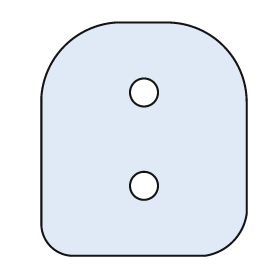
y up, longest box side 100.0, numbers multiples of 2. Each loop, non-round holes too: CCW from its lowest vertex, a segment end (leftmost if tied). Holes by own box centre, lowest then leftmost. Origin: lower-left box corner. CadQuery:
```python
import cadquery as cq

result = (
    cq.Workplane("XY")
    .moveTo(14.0, 0.0)
    .lineTo(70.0, 0.0)
    .threePointArc((82.0, 6.0), (88.0, 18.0))
    .lineTo(88.0, 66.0)
    .threePointArc((78.0, 90.0), (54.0, 100.0))
    .lineTo(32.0, 100.0)
    .threePointArc((10.0, 90.0), (0.0, 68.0))
    .lineTo(0.0, 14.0)
    .threePointArc((4.0, 4.0), (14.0, 0.0))
    .close()
    .moveTo(44.0, 30.0)
    .circle(6.0)
    .moveTo(44.0, 70.0)
    .circle(6.0)
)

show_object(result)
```